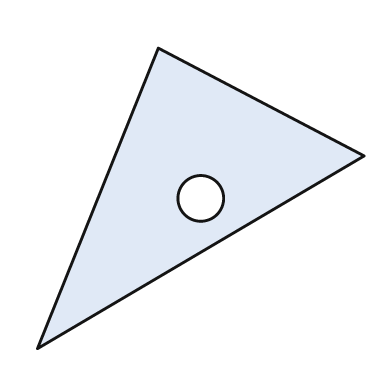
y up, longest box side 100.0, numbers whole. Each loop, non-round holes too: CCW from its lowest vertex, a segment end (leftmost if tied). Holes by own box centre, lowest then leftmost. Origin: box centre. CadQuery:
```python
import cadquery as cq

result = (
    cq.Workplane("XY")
    .moveTo(-50.0, -46.0)
    .lineTo(50.0, 13.0)
    .lineTo(-13.0, 46.0)
    .close()
    .moveTo(0.0, 0.0)
    .circle(7.0)
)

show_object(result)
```